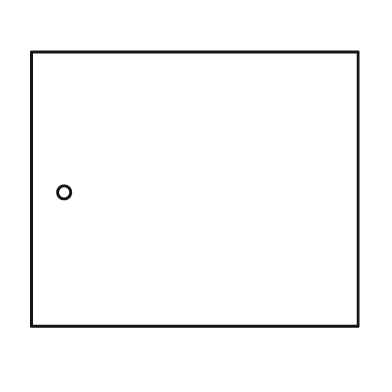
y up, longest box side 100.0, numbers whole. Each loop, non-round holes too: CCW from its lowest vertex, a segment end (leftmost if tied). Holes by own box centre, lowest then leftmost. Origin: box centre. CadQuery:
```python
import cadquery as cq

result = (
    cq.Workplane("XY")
    .moveTo(-50.0, -42.0)
    .lineTo(50.0, -42.0)
    .lineTo(50.0, 42.0)
    .lineTo(-50.0, 42.0)
    .close()
    .moveTo(-40.0, -1.0)
    .circle(2.0)
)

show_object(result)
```